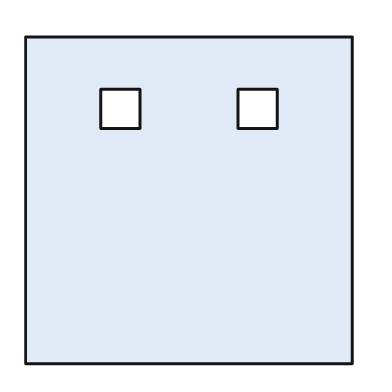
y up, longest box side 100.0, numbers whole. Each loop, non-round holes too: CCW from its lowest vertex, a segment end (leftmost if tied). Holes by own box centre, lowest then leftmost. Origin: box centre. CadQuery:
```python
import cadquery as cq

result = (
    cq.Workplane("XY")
    .moveTo(-50.0, -50.0)
    .lineTo(50.0, -50.0)
    .lineTo(50.0, 50.0)
    .lineTo(-50.0, 50.0)
    .close()
    .moveTo(-27.0, 22.0)
    .lineTo(-15.0, 22.0)
    .lineTo(-15.0, 34.0)
    .lineTo(-27.0, 34.0)
    .close()
    .moveTo(15.0, 22.0)
    .lineTo(27.0, 22.0)
    .lineTo(27.0, 34.0)
    .lineTo(15.0, 34.0)
    .close()
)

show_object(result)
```